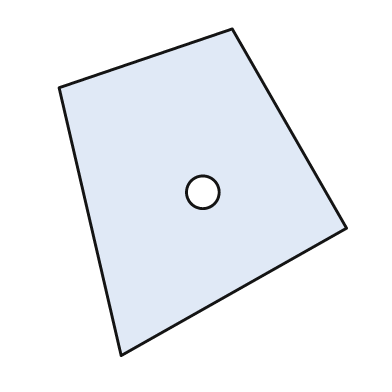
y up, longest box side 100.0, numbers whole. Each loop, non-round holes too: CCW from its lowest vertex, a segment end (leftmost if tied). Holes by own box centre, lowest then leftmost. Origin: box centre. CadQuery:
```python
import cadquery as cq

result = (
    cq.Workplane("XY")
    .moveTo(-25.0, -50.0)
    .lineTo(44.0, -11.0)
    .lineTo(9.0, 50.0)
    .lineTo(-44.0, 32.0)
    .close()
    .moveTo(0.0, 0.0)
    .circle(5.0)
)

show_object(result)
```